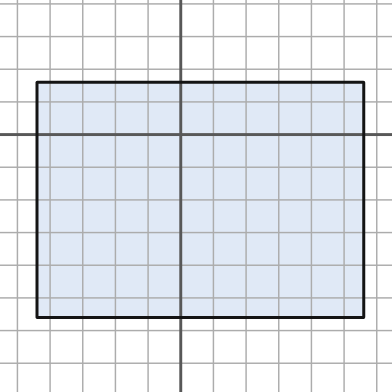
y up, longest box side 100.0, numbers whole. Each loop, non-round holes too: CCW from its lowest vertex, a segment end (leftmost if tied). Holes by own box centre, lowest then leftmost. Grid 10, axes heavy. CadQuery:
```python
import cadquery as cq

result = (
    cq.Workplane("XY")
    .moveTo(-44.0, -56.0)
    .lineTo(56.0, -56.0)
    .lineTo(56.0, 16.0)
    .lineTo(-44.0, 16.0)
    .close()
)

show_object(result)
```